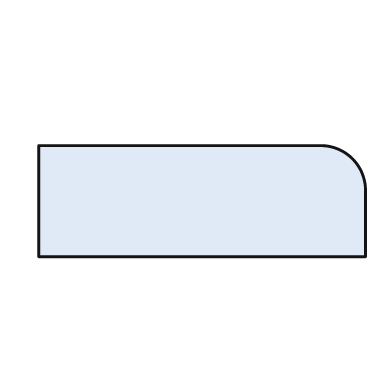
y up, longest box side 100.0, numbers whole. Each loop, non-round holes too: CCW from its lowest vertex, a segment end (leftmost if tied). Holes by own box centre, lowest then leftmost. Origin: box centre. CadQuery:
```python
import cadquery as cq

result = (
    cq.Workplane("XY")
    .moveTo(-50.0, -17.0)
    .lineTo(50.0, -17.0)
    .lineTo(50.0, 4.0)
    .threePointArc((46.0, 13.0), (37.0, 17.0))
    .lineTo(-50.0, 17.0)
    .close()
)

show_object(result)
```